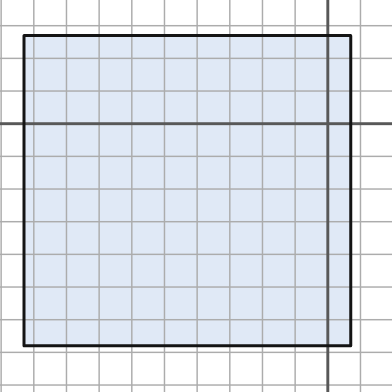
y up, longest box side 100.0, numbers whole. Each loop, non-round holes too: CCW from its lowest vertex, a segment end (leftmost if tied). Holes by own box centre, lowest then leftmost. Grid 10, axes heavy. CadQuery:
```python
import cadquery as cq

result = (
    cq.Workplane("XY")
    .moveTo(-93.0, -68.0)
    .lineTo(7.0, -68.0)
    .lineTo(7.0, 27.0)
    .lineTo(-93.0, 27.0)
    .close()
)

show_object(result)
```